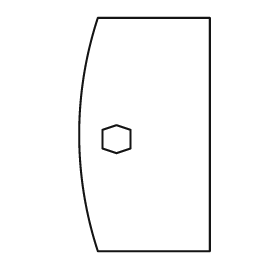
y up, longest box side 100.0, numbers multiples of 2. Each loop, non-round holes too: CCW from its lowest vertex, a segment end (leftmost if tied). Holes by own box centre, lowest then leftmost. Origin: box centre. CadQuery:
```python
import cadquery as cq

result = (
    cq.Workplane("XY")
    .moveTo(-20.0, -50.0)
    .lineTo(28.0, -50.0)
    .lineTo(28.0, 50.0)
    .lineTo(-20.0, 50.0)
    .threePointArc((-28.0, 0.0), (-20.0, -50.0))
    .close()
    .moveTo(-12.0, -8.0)
    .lineTo(-6.0, -6.0)
    .lineTo(-6.0, 2.0)
    .lineTo(-12.0, 4.0)
    .lineTo(-18.0, 2.0)
    .lineTo(-18.0, -6.0)
    .close()
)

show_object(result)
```